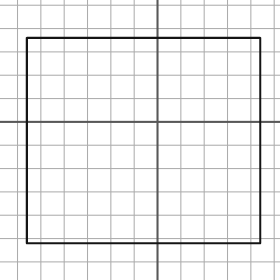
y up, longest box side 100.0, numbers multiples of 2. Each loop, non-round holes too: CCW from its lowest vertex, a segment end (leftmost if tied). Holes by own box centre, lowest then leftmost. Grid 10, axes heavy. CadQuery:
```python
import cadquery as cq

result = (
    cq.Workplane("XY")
    .moveTo(-56.0, -52.0)
    .lineTo(44.0, -52.0)
    .lineTo(44.0, 36.0)
    .lineTo(-56.0, 36.0)
    .close()
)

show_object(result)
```